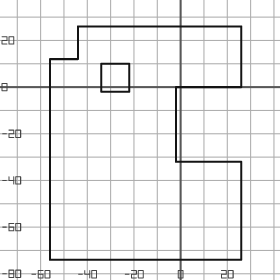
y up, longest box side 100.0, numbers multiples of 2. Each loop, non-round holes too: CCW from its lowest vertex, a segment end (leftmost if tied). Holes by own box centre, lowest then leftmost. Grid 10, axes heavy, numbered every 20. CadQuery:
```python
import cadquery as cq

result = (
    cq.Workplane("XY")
    .moveTo(-56.0, -74.0)
    .lineTo(26.0, -74.0)
    .lineTo(26.0, -32.0)
    .lineTo(-2.0, -32.0)
    .lineTo(-2.0, 0.0)
    .lineTo(26.0, 0.0)
    .lineTo(26.0, 26.0)
    .lineTo(-44.0, 26.0)
    .lineTo(-44.0, 12.0)
    .lineTo(-56.0, 12.0)
    .close()
    .moveTo(-34.0, -2.0)
    .lineTo(-22.0, -2.0)
    .lineTo(-22.0, 10.0)
    .lineTo(-34.0, 10.0)
    .close()
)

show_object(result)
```